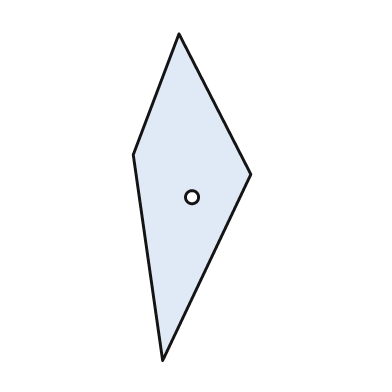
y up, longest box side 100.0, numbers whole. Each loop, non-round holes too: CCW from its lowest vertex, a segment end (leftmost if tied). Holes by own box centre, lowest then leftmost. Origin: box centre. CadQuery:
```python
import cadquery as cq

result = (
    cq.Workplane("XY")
    .moveTo(-9.0, -50.0)
    .lineTo(18.0, 7.0)
    .lineTo(-4.0, 50.0)
    .lineTo(-18.0, 13.0)
    .close()
    .moveTo(0.0, 0.0)
    .circle(2.0)
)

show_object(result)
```